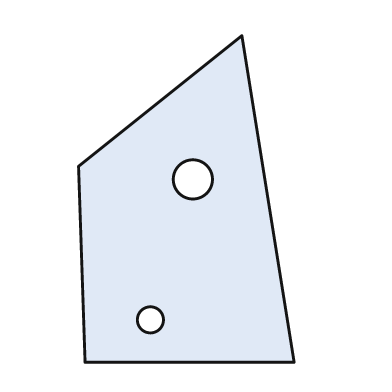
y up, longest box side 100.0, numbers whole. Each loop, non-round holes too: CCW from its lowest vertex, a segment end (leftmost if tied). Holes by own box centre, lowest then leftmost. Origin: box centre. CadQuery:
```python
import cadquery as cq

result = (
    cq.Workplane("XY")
    .moveTo(-31.0, -50.0)
    .lineTo(33.0, -50.0)
    .lineTo(17.0, 50.0)
    .lineTo(-33.0, 10.0)
    .close()
    .moveTo(-11.0, -37.0)
    .circle(4.0)
    .moveTo(2.0, 6.0)
    .circle(6.0)
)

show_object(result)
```